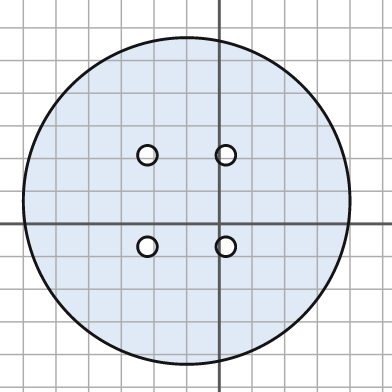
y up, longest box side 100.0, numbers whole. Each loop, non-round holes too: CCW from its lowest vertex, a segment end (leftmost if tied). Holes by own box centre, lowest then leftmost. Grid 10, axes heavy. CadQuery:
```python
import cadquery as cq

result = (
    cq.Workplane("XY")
    .moveTo(-10.0, 7.0)
    .circle(50.0)
    .moveTo(-22.0, -7.0)
    .circle(3.0)
    .moveTo(2.0, -7.0)
    .circle(3.0)
    .moveTo(-22.0, 21.0)
    .circle(3.0)
    .moveTo(2.0, 21.0)
    .circle(3.0)
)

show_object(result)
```